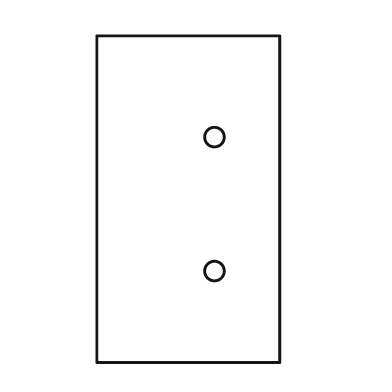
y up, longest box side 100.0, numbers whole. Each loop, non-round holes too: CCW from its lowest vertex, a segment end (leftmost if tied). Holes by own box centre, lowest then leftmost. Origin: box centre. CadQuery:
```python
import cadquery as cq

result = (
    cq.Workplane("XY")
    .moveTo(-28.0, -50.0)
    .lineTo(28.0, -50.0)
    .lineTo(28.0, 50.0)
    .lineTo(-28.0, 50.0)
    .close()
    .moveTo(8.0, -22.0)
    .circle(3.0)
    .moveTo(8.0, 19.0)
    .circle(3.0)
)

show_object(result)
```